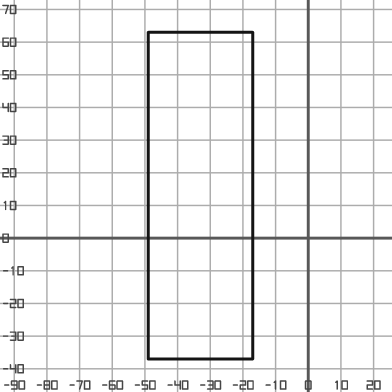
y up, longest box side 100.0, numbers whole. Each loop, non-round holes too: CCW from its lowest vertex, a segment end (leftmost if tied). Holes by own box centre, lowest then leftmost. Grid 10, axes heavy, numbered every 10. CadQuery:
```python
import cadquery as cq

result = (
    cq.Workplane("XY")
    .moveTo(-49.0, -37.0)
    .lineTo(-17.0, -37.0)
    .lineTo(-17.0, 63.0)
    .lineTo(-49.0, 63.0)
    .close()
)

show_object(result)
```